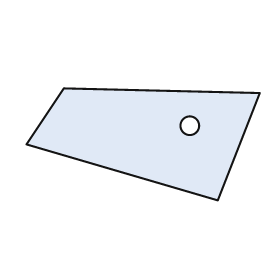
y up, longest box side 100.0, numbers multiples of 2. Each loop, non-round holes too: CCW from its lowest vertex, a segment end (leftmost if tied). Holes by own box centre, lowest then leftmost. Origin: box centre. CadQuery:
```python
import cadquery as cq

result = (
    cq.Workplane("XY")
    .moveTo(32.0, -24.0)
    .lineTo(50.0, 22.0)
    .lineTo(-34.0, 24.0)
    .lineTo(-50.0, 0.0)
    .close()
    .moveTo(20.0, 8.0)
    .circle(4.0)
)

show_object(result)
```